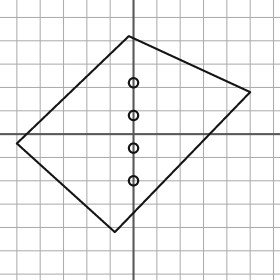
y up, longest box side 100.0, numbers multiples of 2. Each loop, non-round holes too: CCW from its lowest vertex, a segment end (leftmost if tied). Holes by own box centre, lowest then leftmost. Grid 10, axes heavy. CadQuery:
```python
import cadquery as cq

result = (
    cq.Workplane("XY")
    .moveTo(-8.0, -42.0)
    .lineTo(50.0, 18.0)
    .lineTo(-2.0, 42.0)
    .lineTo(-50.0, -4.0)
    .close()
    .moveTo(0.0, -20.0)
    .circle(2.0)
    .moveTo(0.0, -6.0)
    .circle(2.0)
    .moveTo(0.0, 8.0)
    .circle(2.0)
    .moveTo(0.0, 22.0)
    .circle(2.0)
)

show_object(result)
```